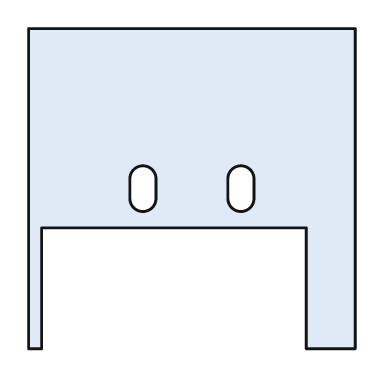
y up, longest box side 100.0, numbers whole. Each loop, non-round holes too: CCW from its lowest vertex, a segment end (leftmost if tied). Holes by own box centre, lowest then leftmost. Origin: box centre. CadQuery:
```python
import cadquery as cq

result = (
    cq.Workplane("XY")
    .moveTo(-50.0, -49.0)
    .lineTo(-46.0, -49.0)
    .lineTo(-46.0, -12.0)
    .lineTo(35.0, -12.0)
    .lineTo(35.0, -49.0)
    .lineTo(50.0, -49.0)
    .lineTo(50.0, 49.0)
    .lineTo(-50.0, 49.0)
    .close()
    .moveTo(-19.0, -3.0)
    .threePointArc((-15.0, -7.0), (-11.0, -3.0))
    .lineTo(-11.0, 3.0)
    .threePointArc((-15.0, 7.0), (-19.0, 3.0))
    .close()
    .moveTo(11.0, -3.0)
    .threePointArc((15.0, -7.0), (19.0, -3.0))
    .lineTo(19.0, 3.0)
    .threePointArc((15.0, 7.0), (11.0, 3.0))
    .close()
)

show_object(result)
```